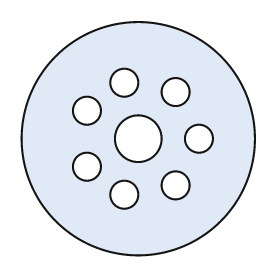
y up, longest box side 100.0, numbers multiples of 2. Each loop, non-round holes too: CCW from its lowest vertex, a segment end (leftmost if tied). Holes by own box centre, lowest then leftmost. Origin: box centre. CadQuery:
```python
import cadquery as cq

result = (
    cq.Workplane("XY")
    .moveTo(0.0, 0.0)
    .circle(50.0)
    .moveTo(-6.0, -24.0)
    .circle(6.0)
    .moveTo(16.0, -20.0)
    .circle(6.0)
    .moveTo(-22.0, -12.0)
    .circle(6.0)
    .moveTo(0.0, 0.0)
    .circle(10.0)
    .moveTo(26.0, 0.0)
    .circle(6.0)
    .moveTo(-22.0, 12.0)
    .circle(6.0)
    .moveTo(16.0, 20.0)
    .circle(6.0)
    .moveTo(-6.0, 24.0)
    .circle(6.0)
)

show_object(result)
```